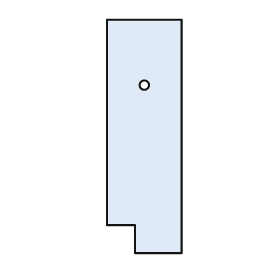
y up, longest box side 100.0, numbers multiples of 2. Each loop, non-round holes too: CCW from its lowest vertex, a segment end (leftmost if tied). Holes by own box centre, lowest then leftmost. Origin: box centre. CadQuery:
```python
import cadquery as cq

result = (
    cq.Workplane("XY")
    .moveTo(-4.0, -50.0)
    .lineTo(16.0, -50.0)
    .lineTo(16.0, 50.0)
    .lineTo(-16.0, 50.0)
    .lineTo(-16.0, -38.0)
    .lineTo(-4.0, -38.0)
    .close()
    .moveTo(0.0, 22.0)
    .circle(2.0)
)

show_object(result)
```